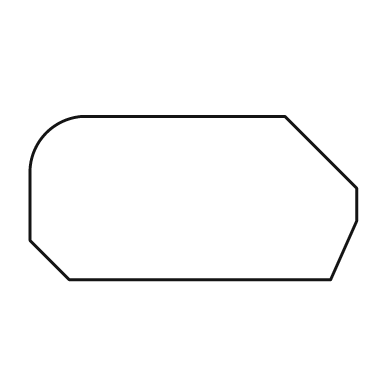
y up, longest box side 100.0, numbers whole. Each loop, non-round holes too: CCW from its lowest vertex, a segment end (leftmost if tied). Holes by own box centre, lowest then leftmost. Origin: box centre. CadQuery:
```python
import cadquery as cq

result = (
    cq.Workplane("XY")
    .moveTo(-38.0, -25.0)
    .lineTo(42.0, -25.0)
    .lineTo(50.0, -7.0)
    .lineTo(50.0, 3.0)
    .lineTo(28.0, 25.0)
    .lineTo(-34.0, 25.0)
    .threePointArc((-45.0, 20.0), (-50.0, 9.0))
    .lineTo(-50.0, -13.0)
    .close()
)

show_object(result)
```